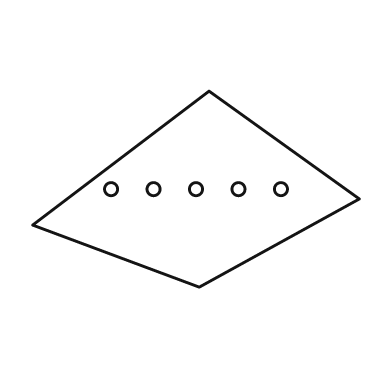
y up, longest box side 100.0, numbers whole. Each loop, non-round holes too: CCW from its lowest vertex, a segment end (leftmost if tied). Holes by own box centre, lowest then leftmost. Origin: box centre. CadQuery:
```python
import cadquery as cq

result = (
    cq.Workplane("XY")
    .moveTo(1.0, -30.0)
    .lineTo(50.0, -3.0)
    .lineTo(4.0, 30.0)
    .lineTo(-50.0, -11.0)
    .close()
    .moveTo(-26.0, 0.0)
    .circle(2.0)
    .moveTo(-13.0, 0.0)
    .circle(2.0)
    .moveTo(0.0, 0.0)
    .circle(2.0)
    .moveTo(13.0, 0.0)
    .circle(2.0)
    .moveTo(26.0, 0.0)
    .circle(2.0)
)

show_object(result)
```